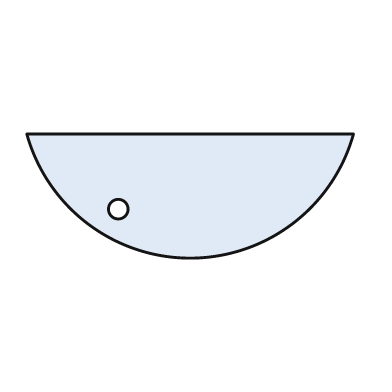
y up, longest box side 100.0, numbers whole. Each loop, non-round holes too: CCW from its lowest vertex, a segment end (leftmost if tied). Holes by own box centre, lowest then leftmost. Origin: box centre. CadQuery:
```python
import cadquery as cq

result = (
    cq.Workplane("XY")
    .moveTo(-50.0, 19.0)
    .threePointArc((0.0, -19.0), (50.0, 19.0))
    .close()
    .moveTo(-22.0, -4.0)
    .circle(3.0)
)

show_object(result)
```